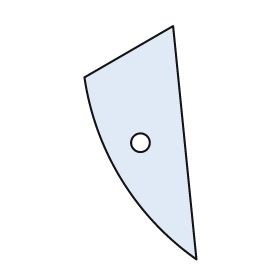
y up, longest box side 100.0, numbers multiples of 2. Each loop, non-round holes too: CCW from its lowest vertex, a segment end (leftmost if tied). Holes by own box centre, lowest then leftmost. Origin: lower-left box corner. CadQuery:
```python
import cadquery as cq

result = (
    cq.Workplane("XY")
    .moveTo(48.0, 0.0)
    .lineTo(38.0, 100.0)
    .lineTo(0.0, 78.0)
    .threePointArc((16.0, 34.0), (48.0, 0.0))
    .close()
    .moveTo(24.0, 50.0)
    .circle(4.0)
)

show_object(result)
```